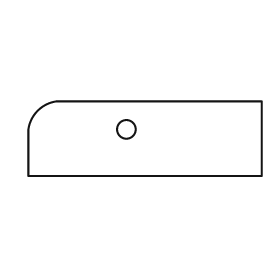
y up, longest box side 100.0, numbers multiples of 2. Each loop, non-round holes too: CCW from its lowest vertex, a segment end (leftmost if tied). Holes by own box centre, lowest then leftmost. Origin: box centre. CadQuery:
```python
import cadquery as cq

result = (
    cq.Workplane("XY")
    .moveTo(-50.0, -16.0)
    .lineTo(50.0, -16.0)
    .lineTo(50.0, 16.0)
    .lineTo(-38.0, 16.0)
    .threePointArc((-46.0, 12.0), (-50.0, 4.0))
    .close()
    .moveTo(-8.0, 4.0)
    .circle(4.0)
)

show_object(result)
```